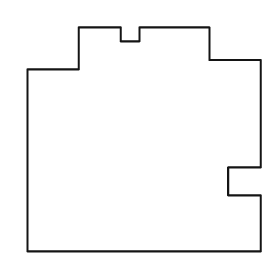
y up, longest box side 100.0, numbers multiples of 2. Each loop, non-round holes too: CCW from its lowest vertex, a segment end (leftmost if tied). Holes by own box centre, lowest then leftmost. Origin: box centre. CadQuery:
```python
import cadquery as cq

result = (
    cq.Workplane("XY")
    .moveTo(-50.0, -48.0)
    .lineTo(50.0, -48.0)
    .lineTo(50.0, -24.0)
    .lineTo(36.0, -24.0)
    .lineTo(36.0, -12.0)
    .lineTo(50.0, -12.0)
    .lineTo(50.0, 34.0)
    .lineTo(28.0, 34.0)
    .lineTo(28.0, 48.0)
    .lineTo(-2.0, 48.0)
    .lineTo(-2.0, 42.0)
    .lineTo(-10.0, 42.0)
    .lineTo(-10.0, 48.0)
    .lineTo(-28.0, 48.0)
    .lineTo(-28.0, 30.0)
    .lineTo(-50.0, 30.0)
    .close()
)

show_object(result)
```